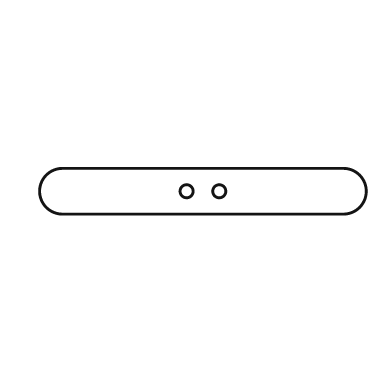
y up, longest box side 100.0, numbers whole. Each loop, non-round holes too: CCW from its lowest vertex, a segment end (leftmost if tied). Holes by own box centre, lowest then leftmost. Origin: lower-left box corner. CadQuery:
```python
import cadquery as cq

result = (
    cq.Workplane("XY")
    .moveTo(7.0, 0.0)
    .lineTo(93.0, 0.0)
    .threePointArc((100.0, 7.0), (93.0, 14.0))
    .lineTo(7.0, 14.0)
    .threePointArc((0.0, 7.0), (7.0, 0.0))
    .close()
    .moveTo(45.0, 7.0)
    .circle(2.0)
    .moveTo(55.0, 7.0)
    .circle(2.0)
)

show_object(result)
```